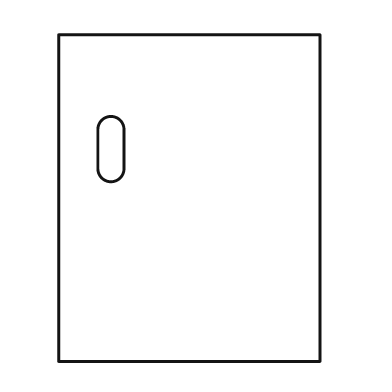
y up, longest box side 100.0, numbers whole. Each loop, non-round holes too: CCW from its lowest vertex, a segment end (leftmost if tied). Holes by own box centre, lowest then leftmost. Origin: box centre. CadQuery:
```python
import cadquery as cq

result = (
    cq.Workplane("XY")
    .moveTo(-40.0, -50.0)
    .lineTo(40.0, -50.0)
    .lineTo(40.0, 50.0)
    .lineTo(-40.0, 50.0)
    .close()
    .moveTo(-28.0, 9.0)
    .threePointArc((-24.0, 5.0), (-20.0, 9.0))
    .lineTo(-20.0, 21.0)
    .threePointArc((-24.0, 25.0), (-28.0, 21.0))
    .close()
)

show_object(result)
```